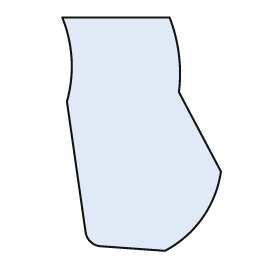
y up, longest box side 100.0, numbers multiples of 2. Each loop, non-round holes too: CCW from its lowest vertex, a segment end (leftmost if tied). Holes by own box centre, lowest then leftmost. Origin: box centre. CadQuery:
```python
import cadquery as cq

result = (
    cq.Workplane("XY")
    .moveTo(10.0, -50.0)
    .threePointArc((26.0, -36.0), (34.0, -16.0))
    .lineTo(16.0, 18.0)
    .threePointArc((16.0, 34.0), (12.0, 50.0))
    .lineTo(-34.0, 50.0)
    .threePointArc((-30.0, 32.0), (-32.0, 14.0))
    .lineTo(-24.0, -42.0)
    .threePointArc((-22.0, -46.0), (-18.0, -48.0))
    .close()
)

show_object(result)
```